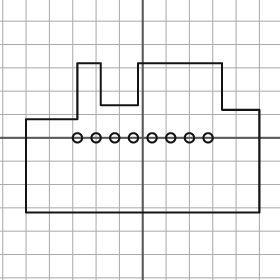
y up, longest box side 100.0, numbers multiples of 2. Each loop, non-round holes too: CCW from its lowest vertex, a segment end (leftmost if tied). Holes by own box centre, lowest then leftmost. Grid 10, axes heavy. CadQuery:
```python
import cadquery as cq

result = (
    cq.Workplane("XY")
    .moveTo(-50.0, -32.0)
    .lineTo(50.0, -32.0)
    .lineTo(50.0, 12.0)
    .lineTo(34.0, 12.0)
    .lineTo(34.0, 32.0)
    .lineTo(-2.0, 32.0)
    .lineTo(-2.0, 14.0)
    .lineTo(-18.0, 14.0)
    .lineTo(-18.0, 32.0)
    .lineTo(-28.0, 32.0)
    .lineTo(-28.0, 8.0)
    .lineTo(-50.0, 8.0)
    .close()
    .moveTo(-28.0, 0.0)
    .circle(2.0)
    .moveTo(-20.0, 0.0)
    .circle(2.0)
    .moveTo(-12.0, 0.0)
    .circle(2.0)
    .moveTo(-4.0, 0.0)
    .circle(2.0)
    .moveTo(4.0, 0.0)
    .circle(2.0)
    .moveTo(12.0, 0.0)
    .circle(2.0)
    .moveTo(20.0, 0.0)
    .circle(2.0)
    .moveTo(28.0, 0.0)
    .circle(2.0)
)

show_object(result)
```